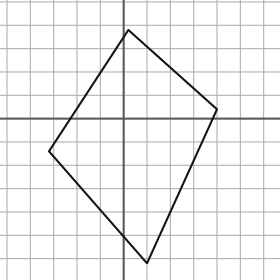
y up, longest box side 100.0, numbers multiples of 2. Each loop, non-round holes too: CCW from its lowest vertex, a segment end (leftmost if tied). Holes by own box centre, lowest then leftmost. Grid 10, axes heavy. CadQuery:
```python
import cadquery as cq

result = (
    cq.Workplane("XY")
    .moveTo(10.0, -62.0)
    .lineTo(40.0, 4.0)
    .lineTo(2.0, 38.0)
    .lineTo(-32.0, -14.0)
    .close()
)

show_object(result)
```